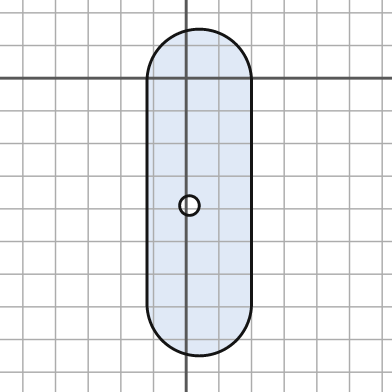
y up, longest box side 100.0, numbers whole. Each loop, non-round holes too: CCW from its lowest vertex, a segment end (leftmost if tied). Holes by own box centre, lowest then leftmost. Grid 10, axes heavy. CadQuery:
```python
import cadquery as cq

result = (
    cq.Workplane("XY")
    .moveTo(-12.0, -69.0)
    .threePointArc((4.0, -85.0), (20.0, -69.0))
    .lineTo(20.0, -1.0)
    .threePointArc((4.0, 15.0), (-12.0, -1.0))
    .close()
    .moveTo(1.0, -39.0)
    .circle(3.0)
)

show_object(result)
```